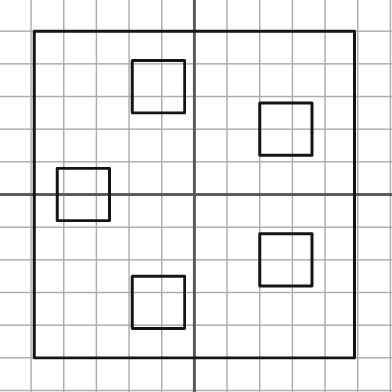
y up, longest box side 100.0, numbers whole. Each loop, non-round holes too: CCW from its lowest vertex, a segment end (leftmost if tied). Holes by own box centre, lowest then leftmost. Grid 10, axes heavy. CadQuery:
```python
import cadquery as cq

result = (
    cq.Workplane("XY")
    .moveTo(-49.0, -50.0)
    .lineTo(49.0, -50.0)
    .lineTo(49.0, 50.0)
    .lineTo(-49.0, 50.0)
    .close()
    .moveTo(-19.0, -41.0)
    .lineTo(-3.0, -41.0)
    .lineTo(-3.0, -25.0)
    .lineTo(-19.0, -25.0)
    .close()
    .moveTo(20.0, -28.0)
    .lineTo(36.0, -28.0)
    .lineTo(36.0, -12.0)
    .lineTo(20.0, -12.0)
    .close()
    .moveTo(-42.0, -8.0)
    .lineTo(-26.0, -8.0)
    .lineTo(-26.0, 8.0)
    .lineTo(-42.0, 8.0)
    .close()
    .moveTo(20.0, 12.0)
    .lineTo(36.0, 12.0)
    .lineTo(36.0, 28.0)
    .lineTo(20.0, 28.0)
    .close()
    .moveTo(-19.0, 25.0)
    .lineTo(-3.0, 25.0)
    .lineTo(-3.0, 41.0)
    .lineTo(-19.0, 41.0)
    .close()
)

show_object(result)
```